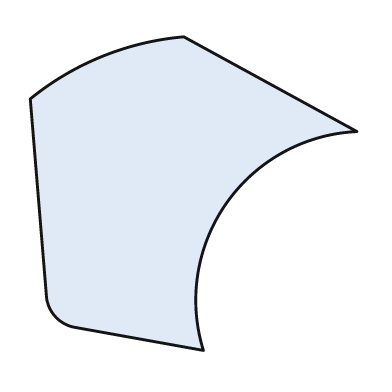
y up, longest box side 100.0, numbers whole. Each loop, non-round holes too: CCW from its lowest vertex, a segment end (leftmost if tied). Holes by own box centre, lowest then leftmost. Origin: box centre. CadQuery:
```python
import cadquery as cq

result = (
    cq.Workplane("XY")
    .moveTo(3.0, -48.0)
    .threePointArc((10.0, -3.0), (50.0, 19.0))
    .lineTo(-3.0, 48.0)
    .threePointArc((-28.0, 42.0), (-50.0, 29.0))
    .lineTo(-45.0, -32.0)
    .threePointArc((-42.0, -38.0), (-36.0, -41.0))
    .close()
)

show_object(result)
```